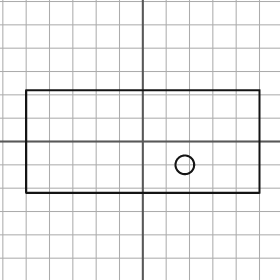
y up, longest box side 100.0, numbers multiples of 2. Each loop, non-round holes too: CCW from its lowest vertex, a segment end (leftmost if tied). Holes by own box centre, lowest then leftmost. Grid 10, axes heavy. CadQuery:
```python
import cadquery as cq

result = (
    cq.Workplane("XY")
    .moveTo(-50.0, -22.0)
    .lineTo(50.0, -22.0)
    .lineTo(50.0, 22.0)
    .lineTo(-50.0, 22.0)
    .close()
    .moveTo(18.0, -10.0)
    .circle(4.0)
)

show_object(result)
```